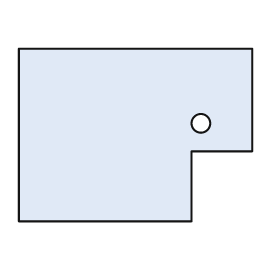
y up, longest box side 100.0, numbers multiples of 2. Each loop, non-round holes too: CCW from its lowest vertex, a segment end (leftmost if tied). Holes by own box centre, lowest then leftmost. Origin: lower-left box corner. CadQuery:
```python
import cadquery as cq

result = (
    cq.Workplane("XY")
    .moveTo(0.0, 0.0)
    .lineTo(74.0, 0.0)
    .lineTo(74.0, 30.0)
    .lineTo(100.0, 30.0)
    .lineTo(100.0, 74.0)
    .lineTo(0.0, 74.0)
    .close()
    .moveTo(78.0, 42.0)
    .circle(4.0)
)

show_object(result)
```